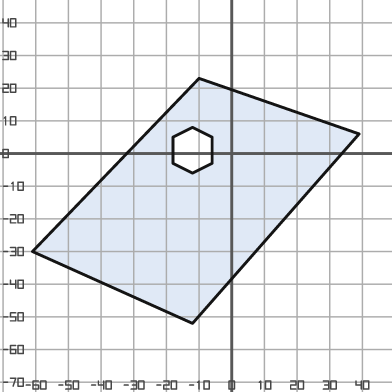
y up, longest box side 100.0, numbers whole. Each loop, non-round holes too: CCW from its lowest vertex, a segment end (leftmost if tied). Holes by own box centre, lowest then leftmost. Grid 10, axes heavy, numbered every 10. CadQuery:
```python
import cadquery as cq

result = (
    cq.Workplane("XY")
    .moveTo(-12.0, -52.0)
    .lineTo(39.0, 6.0)
    .lineTo(-10.0, 23.0)
    .lineTo(-61.0, -30.0)
    .close()
    .moveTo(-12.0, -6.0)
    .lineTo(-6.0, -3.0)
    .lineTo(-6.0, 5.0)
    .lineTo(-12.0, 8.0)
    .lineTo(-18.0, 5.0)
    .lineTo(-18.0, -3.0)
    .close()
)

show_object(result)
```